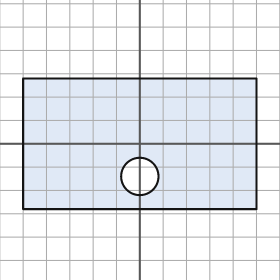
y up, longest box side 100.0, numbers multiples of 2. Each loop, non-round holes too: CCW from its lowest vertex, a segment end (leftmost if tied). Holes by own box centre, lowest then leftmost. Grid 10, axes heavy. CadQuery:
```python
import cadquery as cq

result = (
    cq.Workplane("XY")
    .moveTo(-50.0, -28.0)
    .lineTo(50.0, -28.0)
    .lineTo(50.0, 28.0)
    .lineTo(-50.0, 28.0)
    .close()
    .moveTo(0.0, -14.0)
    .circle(8.0)
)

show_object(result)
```